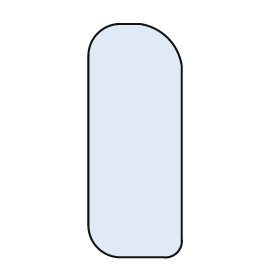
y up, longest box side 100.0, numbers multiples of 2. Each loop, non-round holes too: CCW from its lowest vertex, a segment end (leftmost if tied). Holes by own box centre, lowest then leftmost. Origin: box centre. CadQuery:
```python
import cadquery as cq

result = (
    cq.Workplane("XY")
    .moveTo(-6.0, -50.0)
    .lineTo(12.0, -50.0)
    .threePointArc((18.0, -48.0), (20.0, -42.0))
    .lineTo(20.0, 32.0)
    .threePointArc((14.0, 44.0), (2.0, 50.0))
    .lineTo(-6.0, 50.0)
    .threePointArc((-16.0, 46.0), (-20.0, 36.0))
    .lineTo(-20.0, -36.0)
    .threePointArc((-16.0, -46.0), (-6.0, -50.0))
    .close()
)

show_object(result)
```